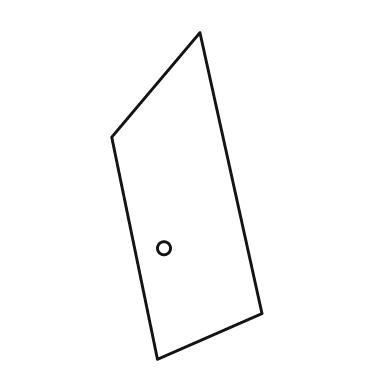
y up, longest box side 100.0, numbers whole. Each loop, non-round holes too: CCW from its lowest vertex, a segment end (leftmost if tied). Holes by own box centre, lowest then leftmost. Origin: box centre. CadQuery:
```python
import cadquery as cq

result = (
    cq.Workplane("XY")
    .moveTo(-9.0, -50.0)
    .lineTo(23.0, -36.0)
    .lineTo(4.0, 50.0)
    .lineTo(-23.0, 18.0)
    .close()
    .moveTo(-7.0, -16.0)
    .circle(2.0)
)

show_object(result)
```